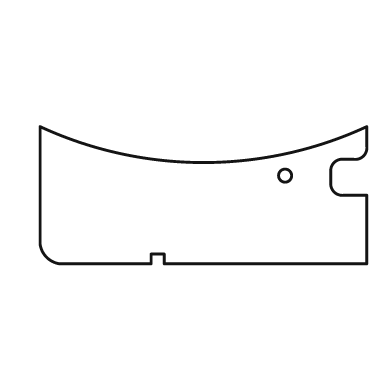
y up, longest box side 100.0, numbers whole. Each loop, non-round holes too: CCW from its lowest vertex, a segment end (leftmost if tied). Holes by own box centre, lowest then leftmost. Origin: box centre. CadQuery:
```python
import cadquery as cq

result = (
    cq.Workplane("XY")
    .moveTo(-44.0, -21.0)
    .lineTo(-16.0, -21.0)
    .lineTo(-16.0, -18.0)
    .lineTo(-12.0, -18.0)
    .lineTo(-12.0, -21.0)
    .lineTo(50.0, -21.0)
    .lineTo(50.0, 0.0)
    .lineTo(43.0, 0.0)
    .threePointArc((40.0, 1.0), (39.0, 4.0))
    .lineTo(39.0, 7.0)
    .threePointArc((40.0, 10.0), (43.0, 11.0))
    .lineTo(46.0, 11.0)
    .threePointArc((49.0, 12.0), (50.0, 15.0))
    .lineTo(50.0, 21.0)
    .threePointArc((0.0, 10.0), (-50.0, 21.0))
    .lineTo(-50.0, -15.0)
    .threePointArc((-48.0, -19.0), (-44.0, -21.0))
    .close()
    .moveTo(25.0, 6.0)
    .circle(2.0)
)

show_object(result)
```